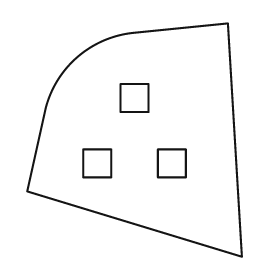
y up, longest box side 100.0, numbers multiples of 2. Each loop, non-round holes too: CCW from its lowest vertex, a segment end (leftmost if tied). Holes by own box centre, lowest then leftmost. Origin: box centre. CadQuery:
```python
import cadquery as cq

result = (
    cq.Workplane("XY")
    .moveTo(46.0, -50.0)
    .lineTo(40.0, 50.0)
    .lineTo(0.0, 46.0)
    .threePointArc((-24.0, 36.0), (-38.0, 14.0))
    .lineTo(-46.0, -22.0)
    .close()
    .moveTo(-22.0, -16.0)
    .lineTo(-10.0, -16.0)
    .lineTo(-10.0, -4.0)
    .lineTo(-22.0, -4.0)
    .close()
    .moveTo(10.0, -16.0)
    .lineTo(22.0, -16.0)
    .lineTo(22.0, -4.0)
    .lineTo(10.0, -4.0)
    .close()
    .moveTo(-6.0, 12.0)
    .lineTo(6.0, 12.0)
    .lineTo(6.0, 24.0)
    .lineTo(-6.0, 24.0)
    .close()
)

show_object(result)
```